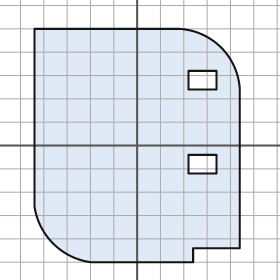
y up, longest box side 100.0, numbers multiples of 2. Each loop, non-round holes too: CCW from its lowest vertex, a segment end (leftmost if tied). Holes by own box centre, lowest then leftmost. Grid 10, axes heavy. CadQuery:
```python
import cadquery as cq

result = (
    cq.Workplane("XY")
    .moveTo(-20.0, -50.0)
    .lineTo(24.0, -50.0)
    .lineTo(24.0, -44.0)
    .lineTo(44.0, -44.0)
    .lineTo(44.0, 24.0)
    .threePointArc((36.0, 42.0), (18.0, 50.0))
    .lineTo(-44.0, 50.0)
    .lineTo(-44.0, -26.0)
    .threePointArc((-36.0, -42.0), (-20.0, -50.0))
    .close()
    .moveTo(22.0, -12.0)
    .lineTo(34.0, -12.0)
    .lineTo(34.0, -4.0)
    .lineTo(22.0, -4.0)
    .close()
    .moveTo(22.0, 24.0)
    .lineTo(34.0, 24.0)
    .lineTo(34.0, 32.0)
    .lineTo(22.0, 32.0)
    .close()
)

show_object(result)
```